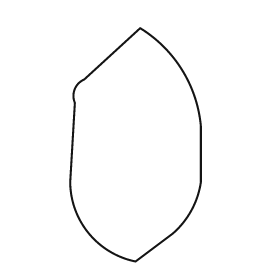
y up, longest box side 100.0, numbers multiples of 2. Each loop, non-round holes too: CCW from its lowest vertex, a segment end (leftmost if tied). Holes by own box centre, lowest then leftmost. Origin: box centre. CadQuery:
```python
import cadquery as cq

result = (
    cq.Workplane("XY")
    .moveTo(0.0, -50.0)
    .lineTo(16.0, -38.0)
    .threePointArc((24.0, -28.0), (28.0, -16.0))
    .lineTo(28.0, 8.0)
    .threePointArc((20.0, 32.0), (2.0, 50.0))
    .lineTo(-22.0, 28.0)
    .threePointArc((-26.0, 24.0), (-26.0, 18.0))
    .lineTo(-28.0, -16.0)
    .threePointArc((-20.0, -38.0), (0.0, -50.0))
    .close()
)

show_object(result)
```